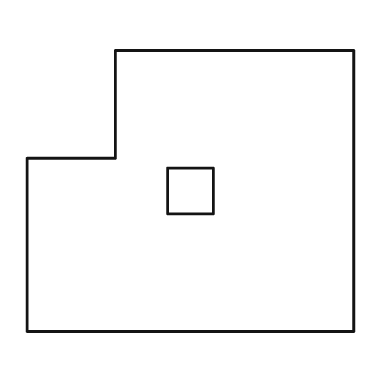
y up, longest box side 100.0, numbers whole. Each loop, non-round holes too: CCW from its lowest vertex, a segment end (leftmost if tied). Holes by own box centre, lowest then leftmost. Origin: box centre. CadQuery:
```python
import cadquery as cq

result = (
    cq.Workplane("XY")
    .moveTo(-50.0, -43.0)
    .lineTo(50.0, -43.0)
    .lineTo(50.0, 43.0)
    .lineTo(-23.0, 43.0)
    .lineTo(-23.0, 10.0)
    .lineTo(-50.0, 10.0)
    .close()
    .moveTo(-7.0, -7.0)
    .lineTo(7.0, -7.0)
    .lineTo(7.0, 7.0)
    .lineTo(-7.0, 7.0)
    .close()
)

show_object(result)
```